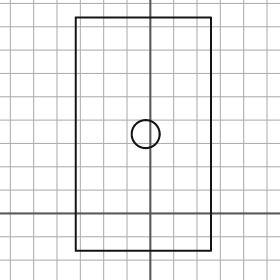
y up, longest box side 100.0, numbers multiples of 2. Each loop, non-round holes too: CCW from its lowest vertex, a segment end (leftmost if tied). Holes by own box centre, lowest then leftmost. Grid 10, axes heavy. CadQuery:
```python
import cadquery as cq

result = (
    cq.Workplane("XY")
    .moveTo(-32.0, -16.0)
    .lineTo(26.0, -16.0)
    .lineTo(26.0, 84.0)
    .lineTo(-32.0, 84.0)
    .close()
    .moveTo(-2.0, 34.0)
    .circle(6.0)
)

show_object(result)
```